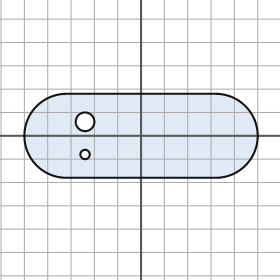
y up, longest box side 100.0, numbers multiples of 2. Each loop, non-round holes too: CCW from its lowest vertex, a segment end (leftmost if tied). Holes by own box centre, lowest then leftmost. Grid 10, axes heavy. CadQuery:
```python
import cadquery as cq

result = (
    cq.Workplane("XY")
    .moveTo(-32.0, -18.0)
    .lineTo(32.0, -18.0)
    .threePointArc((50.0, 0.0), (32.0, 18.0))
    .lineTo(-32.0, 18.0)
    .threePointArc((-50.0, 0.0), (-32.0, -18.0))
    .close()
    .moveTo(-24.0, -8.0)
    .circle(2.0)
    .moveTo(-24.0, 6.0)
    .circle(4.0)
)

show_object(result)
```